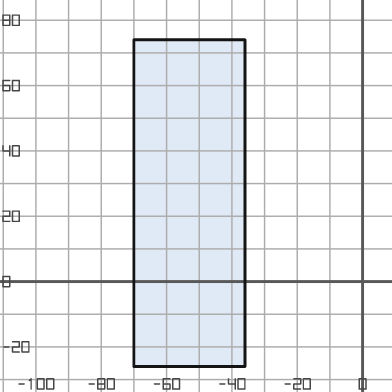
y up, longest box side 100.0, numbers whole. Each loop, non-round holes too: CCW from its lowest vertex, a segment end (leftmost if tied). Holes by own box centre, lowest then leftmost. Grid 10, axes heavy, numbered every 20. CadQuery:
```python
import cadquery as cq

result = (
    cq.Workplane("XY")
    .moveTo(-70.0, -26.0)
    .lineTo(-36.0, -26.0)
    .lineTo(-36.0, 74.0)
    .lineTo(-70.0, 74.0)
    .close()
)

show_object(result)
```